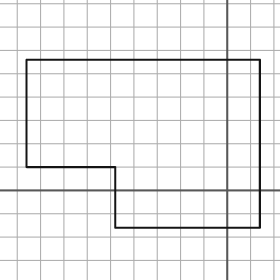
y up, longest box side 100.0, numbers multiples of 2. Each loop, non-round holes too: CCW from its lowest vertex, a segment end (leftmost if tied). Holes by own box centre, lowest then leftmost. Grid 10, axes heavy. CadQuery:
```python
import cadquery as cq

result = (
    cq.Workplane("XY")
    .moveTo(-48.0, -16.0)
    .lineTo(14.0, -16.0)
    .lineTo(14.0, 56.0)
    .lineTo(-86.0, 56.0)
    .lineTo(-86.0, 10.0)
    .lineTo(-48.0, 10.0)
    .close()
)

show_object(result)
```